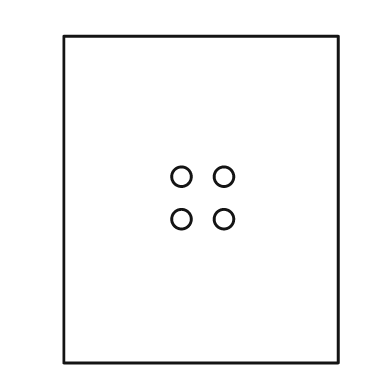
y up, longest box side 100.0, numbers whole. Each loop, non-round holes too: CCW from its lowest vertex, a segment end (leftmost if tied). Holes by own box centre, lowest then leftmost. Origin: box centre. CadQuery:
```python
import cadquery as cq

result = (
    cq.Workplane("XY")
    .moveTo(-42.0, -50.0)
    .lineTo(42.0, -50.0)
    .lineTo(42.0, 50.0)
    .lineTo(-42.0, 50.0)
    .close()
    .moveTo(-6.0, -6.0)
    .circle(3.0)
    .moveTo(7.0, -6.0)
    .circle(3.0)
    .moveTo(-6.0, 7.0)
    .circle(3.0)
    .moveTo(7.0, 7.0)
    .circle(3.0)
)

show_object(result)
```